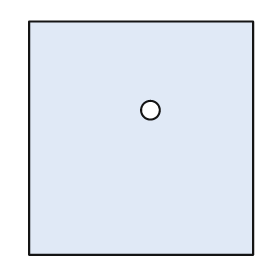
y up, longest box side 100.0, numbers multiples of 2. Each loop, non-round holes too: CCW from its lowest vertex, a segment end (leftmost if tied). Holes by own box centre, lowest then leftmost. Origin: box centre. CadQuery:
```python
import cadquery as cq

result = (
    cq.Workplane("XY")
    .moveTo(-48.0, -50.0)
    .lineTo(48.0, -50.0)
    .lineTo(48.0, 50.0)
    .lineTo(-48.0, 50.0)
    .close()
    .moveTo(4.0, 12.0)
    .circle(4.0)
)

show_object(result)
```